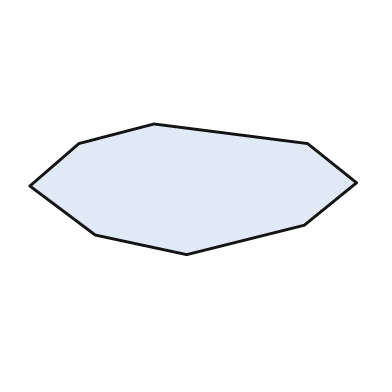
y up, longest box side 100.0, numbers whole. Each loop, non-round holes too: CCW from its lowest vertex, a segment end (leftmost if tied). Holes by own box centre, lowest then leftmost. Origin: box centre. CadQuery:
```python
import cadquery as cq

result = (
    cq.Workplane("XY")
    .moveTo(-2.0, -20.0)
    .lineTo(34.0, -11.0)
    .lineTo(50.0, 2.0)
    .lineTo(35.0, 14.0)
    .lineTo(-12.0, 20.0)
    .lineTo(-35.0, 14.0)
    .lineTo(-50.0, 1.0)
    .lineTo(-30.0, -14.0)
    .close()
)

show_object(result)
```